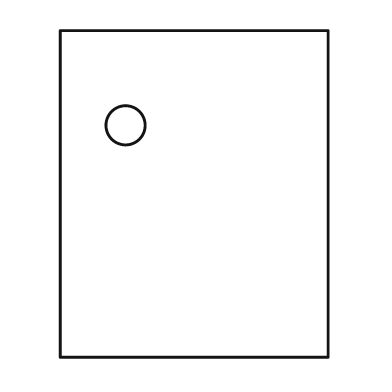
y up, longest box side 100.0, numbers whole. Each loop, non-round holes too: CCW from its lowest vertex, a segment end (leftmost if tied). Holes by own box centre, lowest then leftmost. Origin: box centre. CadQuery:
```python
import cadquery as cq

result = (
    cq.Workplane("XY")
    .moveTo(-41.0, -50.0)
    .lineTo(41.0, -50.0)
    .lineTo(41.0, 50.0)
    .lineTo(-41.0, 50.0)
    .close()
    .moveTo(-21.0, 21.0)
    .circle(6.0)
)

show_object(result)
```